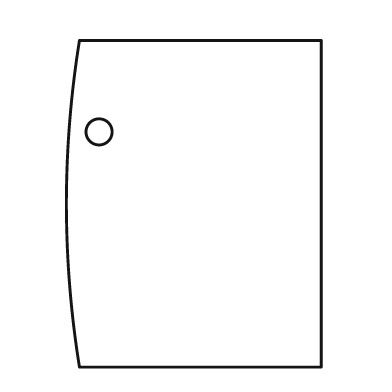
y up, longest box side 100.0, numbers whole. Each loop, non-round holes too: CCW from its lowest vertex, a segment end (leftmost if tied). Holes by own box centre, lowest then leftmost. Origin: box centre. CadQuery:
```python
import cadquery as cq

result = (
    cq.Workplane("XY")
    .moveTo(-35.0, -50.0)
    .lineTo(39.0, -50.0)
    .lineTo(39.0, 50.0)
    .lineTo(-35.0, 50.0)
    .threePointArc((-39.0, 0.0), (-35.0, -50.0))
    .close()
    .moveTo(-29.0, 22.0)
    .circle(4.0)
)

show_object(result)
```